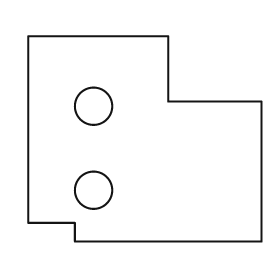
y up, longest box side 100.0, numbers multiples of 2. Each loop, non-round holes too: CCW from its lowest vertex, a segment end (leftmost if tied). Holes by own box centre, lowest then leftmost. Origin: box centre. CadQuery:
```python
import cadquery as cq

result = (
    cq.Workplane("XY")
    .moveTo(-30.0, -44.0)
    .lineTo(50.0, -44.0)
    .lineTo(50.0, 16.0)
    .lineTo(10.0, 16.0)
    .lineTo(10.0, 44.0)
    .lineTo(-50.0, 44.0)
    .lineTo(-50.0, -36.0)
    .lineTo(-30.0, -36.0)
    .close()
    .moveTo(-22.0, -22.0)
    .circle(8.0)
    .moveTo(-22.0, 14.0)
    .circle(8.0)
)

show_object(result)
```